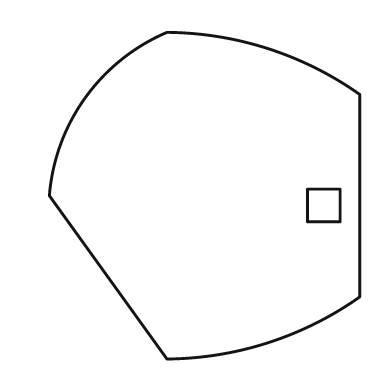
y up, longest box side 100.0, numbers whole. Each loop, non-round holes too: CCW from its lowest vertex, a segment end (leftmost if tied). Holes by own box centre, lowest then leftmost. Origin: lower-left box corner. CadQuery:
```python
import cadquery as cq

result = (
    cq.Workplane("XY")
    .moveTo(36.0, 0.0)
    .threePointArc((67.0, 5.0), (95.0, 19.0))
    .lineTo(95.0, 81.0)
    .threePointArc((67.0, 95.0), (36.0, 100.0))
    .threePointArc((11.0, 80.0), (0.0, 50.0))
    .close()
    .moveTo(79.0, 42.0)
    .lineTo(89.0, 42.0)
    .lineTo(89.0, 52.0)
    .lineTo(79.0, 52.0)
    .close()
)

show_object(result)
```